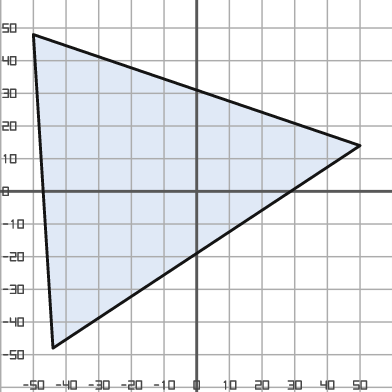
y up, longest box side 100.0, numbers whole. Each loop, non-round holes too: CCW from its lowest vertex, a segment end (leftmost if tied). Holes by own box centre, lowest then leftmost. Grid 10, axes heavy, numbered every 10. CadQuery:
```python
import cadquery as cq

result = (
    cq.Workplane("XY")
    .moveTo(-44.0, -48.0)
    .lineTo(50.0, 14.0)
    .lineTo(-50.0, 48.0)
    .close()
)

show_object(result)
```